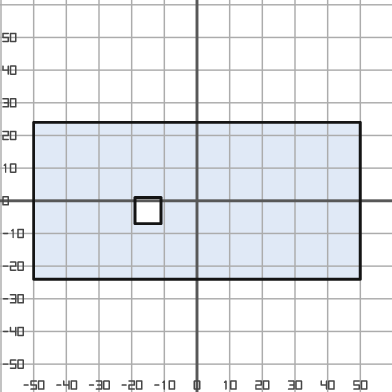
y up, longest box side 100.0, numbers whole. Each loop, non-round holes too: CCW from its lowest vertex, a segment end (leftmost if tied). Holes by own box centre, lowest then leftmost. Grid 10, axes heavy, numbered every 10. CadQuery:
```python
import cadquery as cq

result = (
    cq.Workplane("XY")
    .moveTo(-50.0, -24.0)
    .lineTo(50.0, -24.0)
    .lineTo(50.0, 24.0)
    .lineTo(-50.0, 24.0)
    .close()
    .moveTo(-19.0, -7.0)
    .lineTo(-11.0, -7.0)
    .lineTo(-11.0, 1.0)
    .lineTo(-19.0, 1.0)
    .close()
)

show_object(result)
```